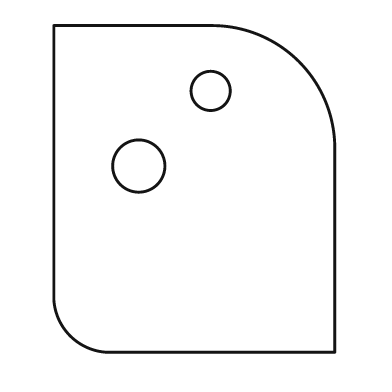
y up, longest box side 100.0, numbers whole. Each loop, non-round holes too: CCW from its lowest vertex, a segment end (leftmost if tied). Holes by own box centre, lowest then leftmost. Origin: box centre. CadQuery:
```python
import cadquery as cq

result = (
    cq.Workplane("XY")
    .moveTo(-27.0, -50.0)
    .lineTo(43.0, -50.0)
    .lineTo(43.0, 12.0)
    .threePointArc((32.0, 39.0), (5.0, 50.0))
    .lineTo(-43.0, 50.0)
    .lineTo(-43.0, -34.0)
    .threePointArc((-38.0, -45.0), (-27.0, -50.0))
    .close()
    .moveTo(-17.0, 7.0)
    .circle(8.0)
    .moveTo(5.0, 30.0)
    .circle(6.0)
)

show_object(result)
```